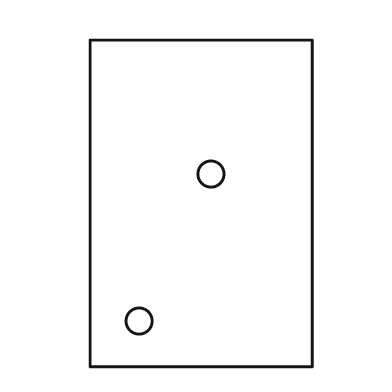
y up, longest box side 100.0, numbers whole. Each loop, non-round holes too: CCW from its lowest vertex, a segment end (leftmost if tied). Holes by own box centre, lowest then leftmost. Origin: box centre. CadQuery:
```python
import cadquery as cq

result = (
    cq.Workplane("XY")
    .moveTo(-34.0, -50.0)
    .lineTo(34.0, -50.0)
    .lineTo(34.0, 50.0)
    .lineTo(-34.0, 50.0)
    .close()
    .moveTo(-19.0, -36.0)
    .circle(4.0)
    .moveTo(3.0, 9.0)
    .circle(4.0)
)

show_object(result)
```